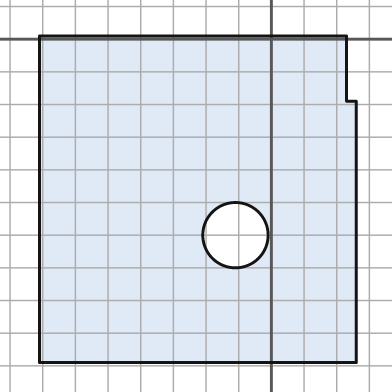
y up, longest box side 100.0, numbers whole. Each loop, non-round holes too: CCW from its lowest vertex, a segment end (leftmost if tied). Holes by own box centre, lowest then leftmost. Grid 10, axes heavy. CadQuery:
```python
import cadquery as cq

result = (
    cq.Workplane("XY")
    .moveTo(-71.0, -99.0)
    .lineTo(26.0, -99.0)
    .lineTo(26.0, -19.0)
    .lineTo(23.0, -19.0)
    .lineTo(23.0, 1.0)
    .lineTo(-71.0, 1.0)
    .close()
    .moveTo(-11.0, -60.0)
    .circle(10.0)
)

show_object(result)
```